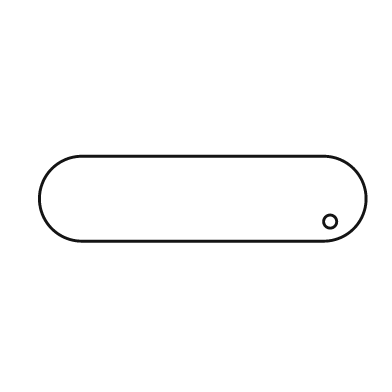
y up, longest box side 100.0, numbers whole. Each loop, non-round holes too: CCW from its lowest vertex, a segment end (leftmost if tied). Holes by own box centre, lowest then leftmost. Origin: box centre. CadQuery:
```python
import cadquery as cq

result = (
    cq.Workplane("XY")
    .moveTo(-37.0, -13.0)
    .lineTo(37.0, -13.0)
    .threePointArc((50.0, 0.0), (37.0, 13.0))
    .lineTo(-37.0, 13.0)
    .threePointArc((-50.0, 0.0), (-37.0, -13.0))
    .close()
    .moveTo(39.0, -7.0)
    .circle(2.0)
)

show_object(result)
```